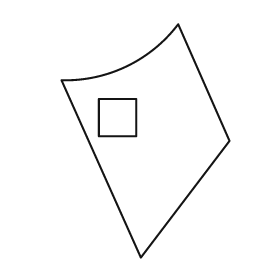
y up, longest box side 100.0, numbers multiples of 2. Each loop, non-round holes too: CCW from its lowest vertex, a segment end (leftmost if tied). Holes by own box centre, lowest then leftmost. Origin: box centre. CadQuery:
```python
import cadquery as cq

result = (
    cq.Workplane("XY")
    .moveTo(-2.0, -50.0)
    .lineTo(36.0, 0.0)
    .lineTo(14.0, 50.0)
    .threePointArc((-8.0, 32.0), (-36.0, 26.0))
    .close()
    .moveTo(-20.0, 2.0)
    .lineTo(-4.0, 2.0)
    .lineTo(-4.0, 18.0)
    .lineTo(-20.0, 18.0)
    .close()
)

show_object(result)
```